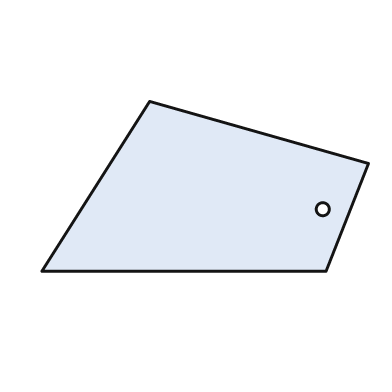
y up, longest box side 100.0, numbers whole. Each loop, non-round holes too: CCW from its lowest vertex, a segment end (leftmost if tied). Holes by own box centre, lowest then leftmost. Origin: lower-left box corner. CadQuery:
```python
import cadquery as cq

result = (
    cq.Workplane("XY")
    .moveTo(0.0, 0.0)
    .lineTo(87.0, 0.0)
    .lineTo(100.0, 33.0)
    .lineTo(33.0, 52.0)
    .close()
    .moveTo(86.0, 19.0)
    .circle(2.0)
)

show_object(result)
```